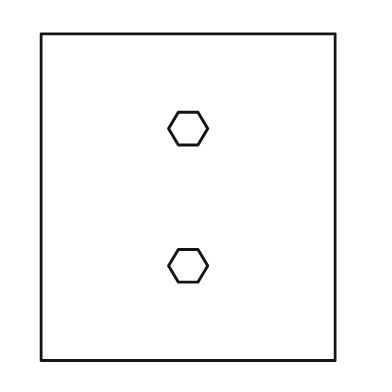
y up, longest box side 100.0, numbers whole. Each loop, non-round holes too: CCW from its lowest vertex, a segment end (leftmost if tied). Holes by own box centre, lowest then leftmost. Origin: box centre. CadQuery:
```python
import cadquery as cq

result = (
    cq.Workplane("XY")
    .moveTo(-45.0, -50.0)
    .lineTo(45.0, -50.0)
    .lineTo(45.0, 50.0)
    .lineTo(-45.0, 50.0)
    .close()
    .moveTo(-3.0, -26.0)
    .lineTo(3.0, -26.0)
    .lineTo(6.0, -21.0)
    .lineTo(3.0, -16.0)
    .lineTo(-3.0, -16.0)
    .lineTo(-6.0, -21.0)
    .close()
    .moveTo(-3.0, 16.0)
    .lineTo(3.0, 16.0)
    .lineTo(6.0, 21.0)
    .lineTo(3.0, 26.0)
    .lineTo(-3.0, 26.0)
    .lineTo(-6.0, 21.0)
    .close()
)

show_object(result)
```